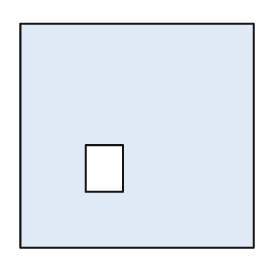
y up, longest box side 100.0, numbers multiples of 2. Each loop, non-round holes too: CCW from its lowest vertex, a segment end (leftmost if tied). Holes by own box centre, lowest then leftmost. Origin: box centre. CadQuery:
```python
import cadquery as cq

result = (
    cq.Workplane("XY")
    .moveTo(-50.0, -48.0)
    .lineTo(50.0, -48.0)
    .lineTo(50.0, 48.0)
    .lineTo(-50.0, 48.0)
    .close()
    .moveTo(-22.0, -24.0)
    .lineTo(-6.0, -24.0)
    .lineTo(-6.0, -4.0)
    .lineTo(-22.0, -4.0)
    .close()
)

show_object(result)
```